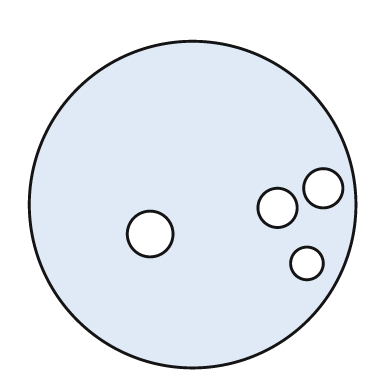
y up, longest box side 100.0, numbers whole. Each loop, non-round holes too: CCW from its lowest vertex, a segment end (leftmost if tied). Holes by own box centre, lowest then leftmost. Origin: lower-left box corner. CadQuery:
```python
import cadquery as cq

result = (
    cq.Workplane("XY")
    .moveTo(50.0, 50.0)
    .circle(50.0)
    .moveTo(85.0, 32.0)
    .circle(5.0)
    .moveTo(37.0, 41.0)
    .circle(7.0)
    .moveTo(76.0, 49.0)
    .circle(6.0)
    .moveTo(90.0, 55.0)
    .circle(6.0)
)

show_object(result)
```